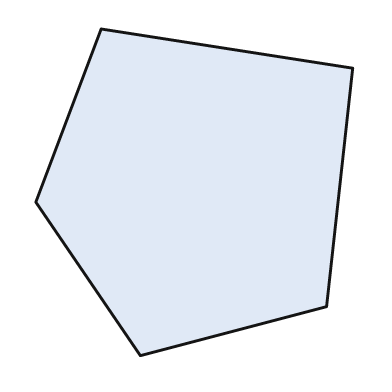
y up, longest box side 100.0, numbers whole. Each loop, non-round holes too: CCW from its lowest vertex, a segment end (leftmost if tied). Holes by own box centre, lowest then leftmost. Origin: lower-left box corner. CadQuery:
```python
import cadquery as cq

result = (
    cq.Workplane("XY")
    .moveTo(32.0, 0.0)
    .lineTo(89.0, 15.0)
    .lineTo(97.0, 88.0)
    .lineTo(20.0, 100.0)
    .lineTo(0.0, 47.0)
    .close()
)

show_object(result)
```